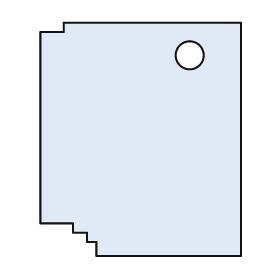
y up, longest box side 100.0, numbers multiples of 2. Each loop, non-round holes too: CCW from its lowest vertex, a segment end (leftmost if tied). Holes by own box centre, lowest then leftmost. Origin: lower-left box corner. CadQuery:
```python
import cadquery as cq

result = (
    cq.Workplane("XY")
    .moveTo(24.0, 0.0)
    .lineTo(86.0, 0.0)
    .lineTo(86.0, 100.0)
    .lineTo(10.0, 100.0)
    .lineTo(10.0, 96.0)
    .lineTo(0.0, 96.0)
    .lineTo(0.0, 14.0)
    .lineTo(14.0, 14.0)
    .lineTo(14.0, 10.0)
    .lineTo(20.0, 10.0)
    .lineTo(20.0, 6.0)
    .lineTo(24.0, 6.0)
    .close()
    .moveTo(64.0, 86.0)
    .circle(6.0)
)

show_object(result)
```